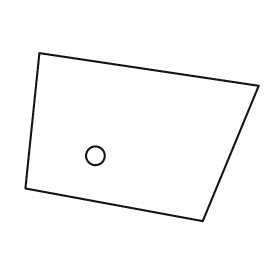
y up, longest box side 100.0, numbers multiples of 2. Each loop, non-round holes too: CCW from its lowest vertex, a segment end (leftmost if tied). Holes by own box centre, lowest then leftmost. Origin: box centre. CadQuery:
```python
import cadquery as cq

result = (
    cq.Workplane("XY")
    .moveTo(26.0, -36.0)
    .lineTo(50.0, 22.0)
    .lineTo(-44.0, 36.0)
    .lineTo(-50.0, -22.0)
    .close()
    .moveTo(-20.0, -8.0)
    .circle(4.0)
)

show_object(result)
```